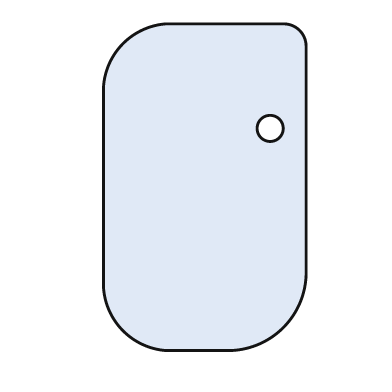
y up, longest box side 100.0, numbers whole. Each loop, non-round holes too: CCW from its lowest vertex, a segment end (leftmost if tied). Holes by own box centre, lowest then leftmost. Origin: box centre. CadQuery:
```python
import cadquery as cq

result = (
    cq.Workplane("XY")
    .moveTo(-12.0, -50.0)
    .lineTo(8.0, -50.0)
    .threePointArc((24.0, -43.0), (31.0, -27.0))
    .lineTo(31.0, 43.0)
    .threePointArc((29.0, 48.0), (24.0, 50.0))
    .lineTo(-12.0, 50.0)
    .threePointArc((-25.0, 44.0), (-31.0, 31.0))
    .lineTo(-31.0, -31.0)
    .threePointArc((-25.0, -44.0), (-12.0, -50.0))
    .close()
    .moveTo(20.0, 18.0)
    .circle(4.0)
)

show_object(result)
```